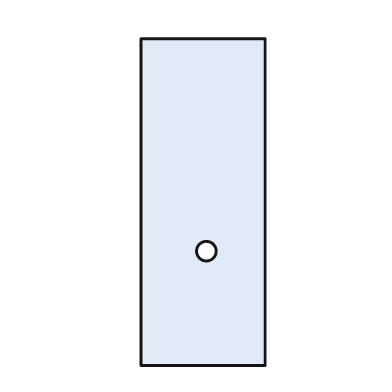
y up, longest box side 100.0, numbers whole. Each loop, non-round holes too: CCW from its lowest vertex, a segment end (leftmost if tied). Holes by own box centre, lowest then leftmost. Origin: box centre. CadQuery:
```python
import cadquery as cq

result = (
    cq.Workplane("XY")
    .moveTo(-19.0, -50.0)
    .lineTo(19.0, -50.0)
    .lineTo(19.0, 50.0)
    .lineTo(-19.0, 50.0)
    .close()
    .moveTo(1.0, -15.0)
    .circle(3.0)
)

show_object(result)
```